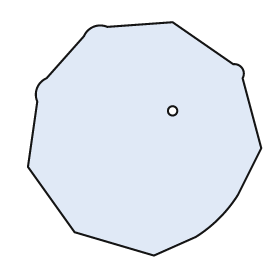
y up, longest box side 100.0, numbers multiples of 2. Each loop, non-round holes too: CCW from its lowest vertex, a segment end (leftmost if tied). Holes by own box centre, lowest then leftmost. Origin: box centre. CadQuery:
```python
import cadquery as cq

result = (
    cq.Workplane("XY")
    .moveTo(4.0, -50.0)
    .lineTo(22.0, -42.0)
    .threePointArc((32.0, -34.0), (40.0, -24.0))
    .lineTo(50.0, -4.0)
    .lineTo(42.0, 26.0)
    .threePointArc((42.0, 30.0), (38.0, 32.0))
    .lineTo(12.0, 50.0)
    .lineTo(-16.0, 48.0)
    .threePointArc((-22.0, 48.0), (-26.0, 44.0))
    .lineTo(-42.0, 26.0)
    .threePointArc((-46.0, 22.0), (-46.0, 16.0))
    .lineTo(-50.0, -12.0)
    .lineTo(-30.0, -40.0)
    .close()
    .moveTo(12.0, 12.0)
    .circle(2.0)
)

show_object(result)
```